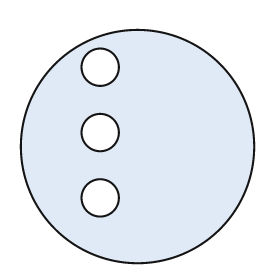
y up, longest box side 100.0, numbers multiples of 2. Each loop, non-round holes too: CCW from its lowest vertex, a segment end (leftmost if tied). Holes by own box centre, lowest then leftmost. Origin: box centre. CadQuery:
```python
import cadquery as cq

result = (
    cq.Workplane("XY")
    .moveTo(0.0, 0.0)
    .circle(50.0)
    .moveTo(-16.0, -22.0)
    .circle(8.0)
    .moveTo(-16.0, 6.0)
    .circle(8.0)
    .moveTo(-16.0, 34.0)
    .circle(8.0)
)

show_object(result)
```